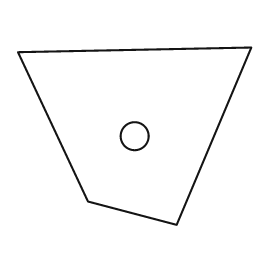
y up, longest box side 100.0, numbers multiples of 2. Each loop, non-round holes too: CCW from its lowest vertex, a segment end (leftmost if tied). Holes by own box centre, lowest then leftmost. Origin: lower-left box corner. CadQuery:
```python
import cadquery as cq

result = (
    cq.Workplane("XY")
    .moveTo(68.0, 0.0)
    .lineTo(100.0, 76.0)
    .lineTo(0.0, 74.0)
    .lineTo(30.0, 10.0)
    .close()
    .moveTo(50.0, 38.0)
    .circle(6.0)
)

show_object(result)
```